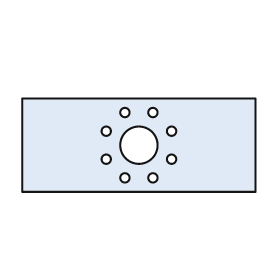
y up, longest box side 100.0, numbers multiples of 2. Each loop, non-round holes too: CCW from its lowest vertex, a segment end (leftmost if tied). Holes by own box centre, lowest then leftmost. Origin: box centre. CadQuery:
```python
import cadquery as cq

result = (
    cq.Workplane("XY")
    .moveTo(-50.0, -20.0)
    .lineTo(50.0, -20.0)
    .lineTo(50.0, 20.0)
    .lineTo(-50.0, 20.0)
    .close()
    .moveTo(-6.0, -14.0)
    .circle(2.0)
    .moveTo(6.0, -14.0)
    .circle(2.0)
    .moveTo(-14.0, -6.0)
    .circle(2.0)
    .moveTo(14.0, -6.0)
    .circle(2.0)
    .moveTo(0.0, 0.0)
    .circle(8.0)
    .moveTo(-14.0, 6.0)
    .circle(2.0)
    .moveTo(14.0, 6.0)
    .circle(2.0)
    .moveTo(-6.0, 14.0)
    .circle(2.0)
    .moveTo(6.0, 14.0)
    .circle(2.0)
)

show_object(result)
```